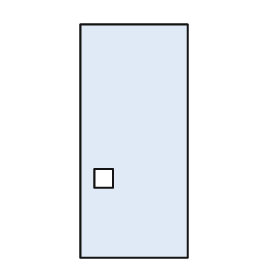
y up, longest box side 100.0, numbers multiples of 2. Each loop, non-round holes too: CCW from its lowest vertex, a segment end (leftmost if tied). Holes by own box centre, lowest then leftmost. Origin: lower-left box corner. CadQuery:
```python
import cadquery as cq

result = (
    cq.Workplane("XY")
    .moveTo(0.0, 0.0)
    .lineTo(46.0, 0.0)
    .lineTo(46.0, 100.0)
    .lineTo(0.0, 100.0)
    .close()
    .moveTo(6.0, 30.0)
    .lineTo(14.0, 30.0)
    .lineTo(14.0, 38.0)
    .lineTo(6.0, 38.0)
    .close()
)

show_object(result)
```